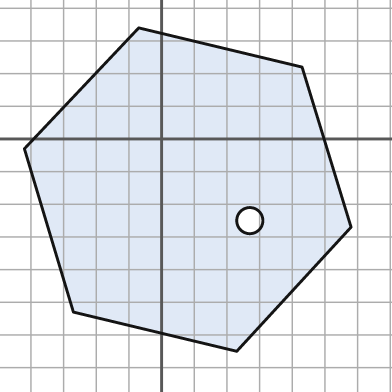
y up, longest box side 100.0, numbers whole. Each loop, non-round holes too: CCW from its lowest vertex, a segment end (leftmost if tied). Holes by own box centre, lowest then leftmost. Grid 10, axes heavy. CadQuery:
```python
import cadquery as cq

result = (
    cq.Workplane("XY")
    .moveTo(23.0, -65.0)
    .lineTo(58.0, -27.0)
    .lineTo(43.0, 22.0)
    .lineTo(-7.0, 34.0)
    .lineTo(-42.0, -3.0)
    .lineTo(-27.0, -53.0)
    .close()
    .moveTo(27.0, -25.0)
    .circle(4.0)
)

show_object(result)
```